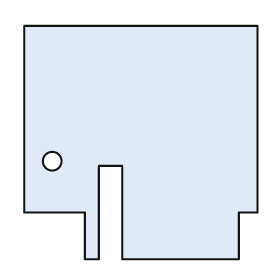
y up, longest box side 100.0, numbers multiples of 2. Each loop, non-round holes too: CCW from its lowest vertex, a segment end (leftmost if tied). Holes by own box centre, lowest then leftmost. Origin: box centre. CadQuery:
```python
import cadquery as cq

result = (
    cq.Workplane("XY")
    .moveTo(-24.0, -50.0)
    .lineTo(-18.0, -50.0)
    .lineTo(-18.0, -10.0)
    .lineTo(-8.0, -10.0)
    .lineTo(-8.0, -50.0)
    .lineTo(42.0, -50.0)
    .lineTo(42.0, -30.0)
    .lineTo(50.0, -30.0)
    .lineTo(50.0, 50.0)
    .lineTo(-50.0, 50.0)
    .lineTo(-50.0, -30.0)
    .lineTo(-24.0, -30.0)
    .close()
    .moveTo(-38.0, -8.0)
    .circle(4.0)
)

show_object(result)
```